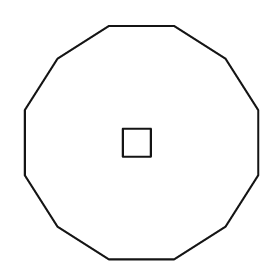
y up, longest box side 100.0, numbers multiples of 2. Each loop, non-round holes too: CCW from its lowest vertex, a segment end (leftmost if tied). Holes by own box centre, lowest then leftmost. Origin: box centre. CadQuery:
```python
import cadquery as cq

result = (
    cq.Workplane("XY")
    .moveTo(-14.0, -50.0)
    .lineTo(14.0, -50.0)
    .lineTo(36.0, -36.0)
    .lineTo(50.0, -14.0)
    .lineTo(50.0, 14.0)
    .lineTo(36.0, 36.0)
    .lineTo(14.0, 50.0)
    .lineTo(-14.0, 50.0)
    .lineTo(-36.0, 36.0)
    .lineTo(-50.0, 14.0)
    .lineTo(-50.0, -14.0)
    .lineTo(-36.0, -36.0)
    .close()
    .moveTo(-8.0, -6.0)
    .lineTo(4.0, -6.0)
    .lineTo(4.0, 6.0)
    .lineTo(-8.0, 6.0)
    .close()
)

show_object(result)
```